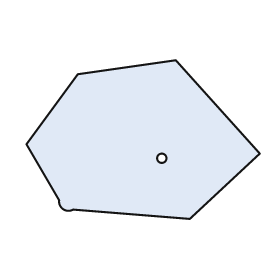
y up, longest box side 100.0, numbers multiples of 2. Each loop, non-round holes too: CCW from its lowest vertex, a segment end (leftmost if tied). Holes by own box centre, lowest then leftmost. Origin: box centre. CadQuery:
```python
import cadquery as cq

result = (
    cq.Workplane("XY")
    .moveTo(20.0, -34.0)
    .lineTo(50.0, -6.0)
    .lineTo(14.0, 34.0)
    .lineTo(-28.0, 28.0)
    .lineTo(-50.0, -2.0)
    .lineTo(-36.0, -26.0)
    .threePointArc((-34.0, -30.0), (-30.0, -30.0))
    .close()
    .moveTo(8.0, -8.0)
    .circle(2.0)
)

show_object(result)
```